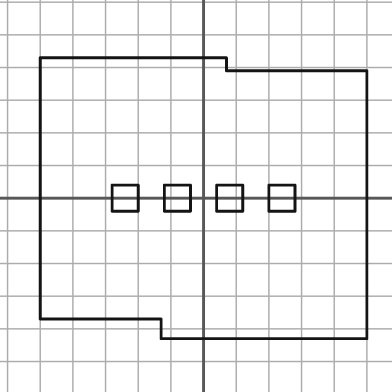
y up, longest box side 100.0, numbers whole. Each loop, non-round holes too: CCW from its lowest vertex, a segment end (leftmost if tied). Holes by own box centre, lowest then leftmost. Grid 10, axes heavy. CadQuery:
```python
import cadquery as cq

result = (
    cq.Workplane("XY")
    .moveTo(-13.0, -43.0)
    .lineTo(50.0, -43.0)
    .lineTo(50.0, 39.0)
    .lineTo(7.0, 39.0)
    .lineTo(7.0, 43.0)
    .lineTo(-50.0, 43.0)
    .lineTo(-50.0, -37.0)
    .lineTo(-13.0, -37.0)
    .close()
    .moveTo(-28.0, -4.0)
    .lineTo(-20.0, -4.0)
    .lineTo(-20.0, 4.0)
    .lineTo(-28.0, 4.0)
    .close()
    .moveTo(-12.0, -4.0)
    .lineTo(-4.0, -4.0)
    .lineTo(-4.0, 4.0)
    .lineTo(-12.0, 4.0)
    .close()
    .moveTo(4.0, -4.0)
    .lineTo(12.0, -4.0)
    .lineTo(12.0, 4.0)
    .lineTo(4.0, 4.0)
    .close()
    .moveTo(20.0, -4.0)
    .lineTo(28.0, -4.0)
    .lineTo(28.0, 4.0)
    .lineTo(20.0, 4.0)
    .close()
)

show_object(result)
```